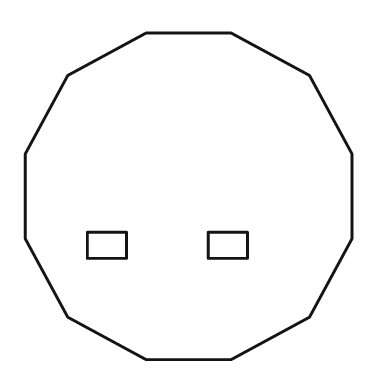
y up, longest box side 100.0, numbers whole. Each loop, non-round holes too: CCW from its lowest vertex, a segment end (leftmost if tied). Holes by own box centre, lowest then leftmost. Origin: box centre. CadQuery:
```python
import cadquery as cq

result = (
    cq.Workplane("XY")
    .moveTo(-13.0, -50.0)
    .lineTo(13.0, -50.0)
    .lineTo(37.0, -37.0)
    .lineTo(50.0, -13.0)
    .lineTo(50.0, 13.0)
    .lineTo(37.0, 37.0)
    .lineTo(13.0, 50.0)
    .lineTo(-13.0, 50.0)
    .lineTo(-37.0, 37.0)
    .lineTo(-50.0, 13.0)
    .lineTo(-50.0, -13.0)
    .lineTo(-37.0, -37.0)
    .close()
    .moveTo(-31.0, -19.0)
    .lineTo(-19.0, -19.0)
    .lineTo(-19.0, -11.0)
    .lineTo(-31.0, -11.0)
    .close()
    .moveTo(6.0, -19.0)
    .lineTo(18.0, -19.0)
    .lineTo(18.0, -11.0)
    .lineTo(6.0, -11.0)
    .close()
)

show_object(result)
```